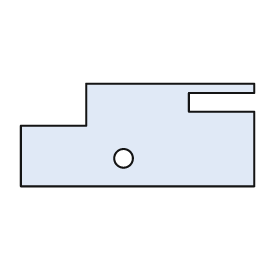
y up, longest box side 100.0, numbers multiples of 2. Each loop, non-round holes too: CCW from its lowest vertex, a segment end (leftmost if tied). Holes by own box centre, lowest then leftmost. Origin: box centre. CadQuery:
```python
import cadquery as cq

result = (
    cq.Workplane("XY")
    .moveTo(-50.0, -22.0)
    .lineTo(50.0, -22.0)
    .lineTo(50.0, 10.0)
    .lineTo(22.0, 10.0)
    .lineTo(22.0, 18.0)
    .lineTo(50.0, 18.0)
    .lineTo(50.0, 22.0)
    .lineTo(-22.0, 22.0)
    .lineTo(-22.0, 4.0)
    .lineTo(-50.0, 4.0)
    .close()
    .moveTo(-6.0, -10.0)
    .circle(4.0)
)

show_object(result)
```